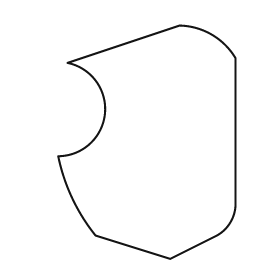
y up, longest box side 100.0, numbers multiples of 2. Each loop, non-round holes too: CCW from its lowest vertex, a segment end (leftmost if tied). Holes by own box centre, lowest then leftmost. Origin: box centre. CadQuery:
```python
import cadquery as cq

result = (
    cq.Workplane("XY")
    .moveTo(10.0, -50.0)
    .lineTo(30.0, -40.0)
    .threePointArc((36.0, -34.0), (38.0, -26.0))
    .lineTo(38.0, 36.0)
    .threePointArc((28.0, 46.0), (14.0, 50.0))
    .lineTo(-34.0, 34.0)
    .threePointArc((-18.0, 12.0), (-38.0, -6.0))
    .threePointArc((-32.0, -24.0), (-22.0, -40.0))
    .close()
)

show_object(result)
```